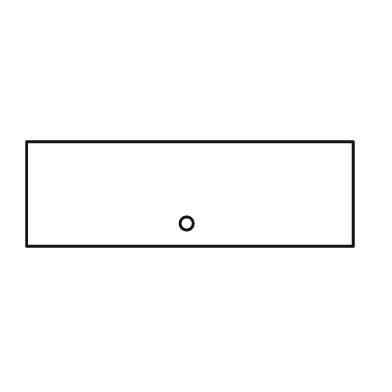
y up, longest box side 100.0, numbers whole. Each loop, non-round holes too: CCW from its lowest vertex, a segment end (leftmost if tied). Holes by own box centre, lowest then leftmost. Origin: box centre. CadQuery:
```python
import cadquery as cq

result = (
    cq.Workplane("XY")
    .moveTo(-50.0, -16.0)
    .lineTo(50.0, -16.0)
    .lineTo(50.0, 16.0)
    .lineTo(-50.0, 16.0)
    .close()
    .moveTo(-1.0, -9.0)
    .circle(2.0)
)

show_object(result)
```